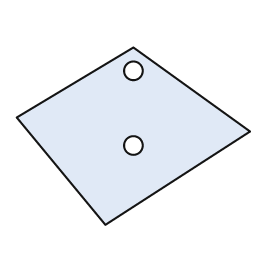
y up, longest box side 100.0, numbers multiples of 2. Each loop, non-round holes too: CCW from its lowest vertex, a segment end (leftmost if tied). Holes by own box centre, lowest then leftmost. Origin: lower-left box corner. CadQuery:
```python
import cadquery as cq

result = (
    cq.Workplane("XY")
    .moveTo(38.0, 0.0)
    .lineTo(100.0, 40.0)
    .lineTo(50.0, 76.0)
    .lineTo(0.0, 46.0)
    .close()
    .moveTo(50.0, 34.0)
    .circle(4.0)
    .moveTo(50.0, 66.0)
    .circle(4.0)
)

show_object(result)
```